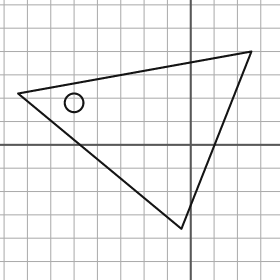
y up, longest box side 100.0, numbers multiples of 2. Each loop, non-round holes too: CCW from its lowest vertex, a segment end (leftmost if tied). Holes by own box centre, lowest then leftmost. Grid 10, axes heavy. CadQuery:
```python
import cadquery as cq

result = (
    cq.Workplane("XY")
    .moveTo(-4.0, -36.0)
    .lineTo(26.0, 40.0)
    .lineTo(-74.0, 22.0)
    .close()
    .moveTo(-50.0, 18.0)
    .circle(4.0)
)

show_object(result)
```